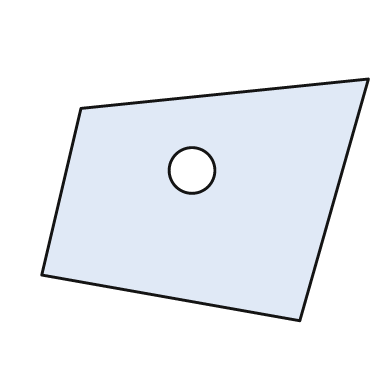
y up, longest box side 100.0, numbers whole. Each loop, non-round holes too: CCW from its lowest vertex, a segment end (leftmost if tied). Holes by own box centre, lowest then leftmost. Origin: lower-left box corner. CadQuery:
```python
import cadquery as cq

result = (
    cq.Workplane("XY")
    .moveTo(79.0, 0.0)
    .lineTo(100.0, 74.0)
    .lineTo(12.0, 65.0)
    .lineTo(0.0, 14.0)
    .close()
    .moveTo(46.0, 46.0)
    .circle(7.0)
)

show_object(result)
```